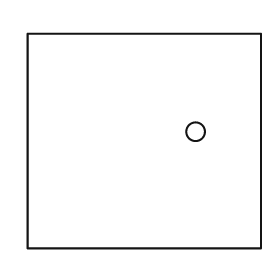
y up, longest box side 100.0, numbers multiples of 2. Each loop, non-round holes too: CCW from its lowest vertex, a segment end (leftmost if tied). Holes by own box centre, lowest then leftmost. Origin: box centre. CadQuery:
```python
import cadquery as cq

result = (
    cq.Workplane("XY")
    .moveTo(-50.0, -46.0)
    .lineTo(50.0, -46.0)
    .lineTo(50.0, 46.0)
    .lineTo(-50.0, 46.0)
    .close()
    .moveTo(22.0, 4.0)
    .circle(4.0)
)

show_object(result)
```